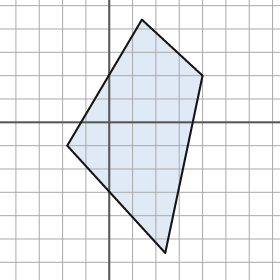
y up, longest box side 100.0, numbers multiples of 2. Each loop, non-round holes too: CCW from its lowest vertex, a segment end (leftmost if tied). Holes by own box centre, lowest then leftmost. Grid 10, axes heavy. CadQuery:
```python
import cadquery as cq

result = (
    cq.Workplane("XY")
    .moveTo(24.0, -56.0)
    .lineTo(40.0, 20.0)
    .lineTo(14.0, 44.0)
    .lineTo(-18.0, -10.0)
    .close()
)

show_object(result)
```